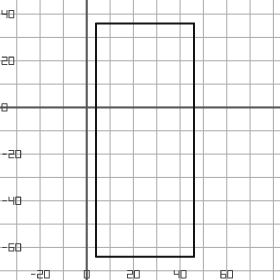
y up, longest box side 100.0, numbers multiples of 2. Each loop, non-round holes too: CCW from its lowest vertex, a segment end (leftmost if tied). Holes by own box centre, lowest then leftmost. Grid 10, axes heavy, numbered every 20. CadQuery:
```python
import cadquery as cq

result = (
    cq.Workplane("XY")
    .moveTo(4.0, -64.0)
    .lineTo(46.0, -64.0)
    .lineTo(46.0, 36.0)
    .lineTo(4.0, 36.0)
    .close()
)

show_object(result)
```